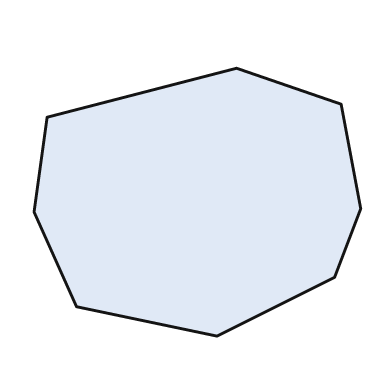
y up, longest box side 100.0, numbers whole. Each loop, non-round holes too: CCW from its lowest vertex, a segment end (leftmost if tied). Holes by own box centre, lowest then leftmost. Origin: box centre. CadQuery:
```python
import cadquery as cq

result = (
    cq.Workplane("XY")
    .moveTo(6.0, -41.0)
    .lineTo(42.0, -23.0)
    .lineTo(50.0, -2.0)
    .lineTo(44.0, 30.0)
    .lineTo(12.0, 41.0)
    .lineTo(-46.0, 26.0)
    .lineTo(-50.0, -3.0)
    .lineTo(-37.0, -32.0)
    .close()
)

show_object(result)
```